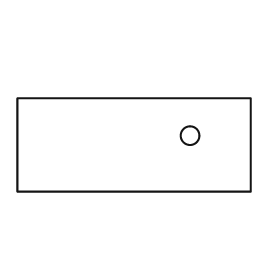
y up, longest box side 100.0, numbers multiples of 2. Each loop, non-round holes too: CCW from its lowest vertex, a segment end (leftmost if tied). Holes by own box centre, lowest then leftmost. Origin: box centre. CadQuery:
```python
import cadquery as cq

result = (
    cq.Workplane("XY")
    .moveTo(-50.0, -20.0)
    .lineTo(50.0, -20.0)
    .lineTo(50.0, 20.0)
    .lineTo(-50.0, 20.0)
    .close()
    .moveTo(24.0, 4.0)
    .circle(4.0)
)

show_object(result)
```